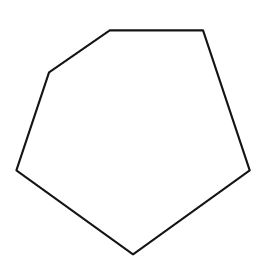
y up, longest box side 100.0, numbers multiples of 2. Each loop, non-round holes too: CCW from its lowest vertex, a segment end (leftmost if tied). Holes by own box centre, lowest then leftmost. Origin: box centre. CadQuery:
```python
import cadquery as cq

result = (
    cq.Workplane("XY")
    .moveTo(0.0, -48.0)
    .lineTo(50.0, -12.0)
    .lineTo(30.0, 48.0)
    .lineTo(-10.0, 48.0)
    .lineTo(-36.0, 30.0)
    .lineTo(-50.0, -12.0)
    .close()
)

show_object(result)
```